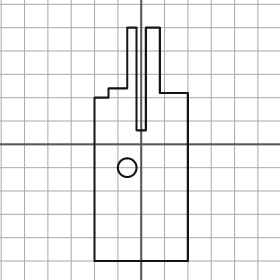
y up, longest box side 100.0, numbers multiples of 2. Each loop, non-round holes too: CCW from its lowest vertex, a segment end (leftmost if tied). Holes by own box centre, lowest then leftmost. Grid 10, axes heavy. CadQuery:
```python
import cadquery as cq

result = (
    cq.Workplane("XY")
    .moveTo(-20.0, -50.0)
    .lineTo(20.0, -50.0)
    .lineTo(20.0, 22.0)
    .lineTo(8.0, 22.0)
    .lineTo(8.0, 50.0)
    .lineTo(2.0, 50.0)
    .lineTo(2.0, 6.0)
    .lineTo(-2.0, 6.0)
    .lineTo(-2.0, 50.0)
    .lineTo(-6.0, 50.0)
    .lineTo(-6.0, 24.0)
    .lineTo(-14.0, 24.0)
    .lineTo(-14.0, 20.0)
    .lineTo(-20.0, 20.0)
    .close()
    .moveTo(-6.0, -10.0)
    .circle(4.0)
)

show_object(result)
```